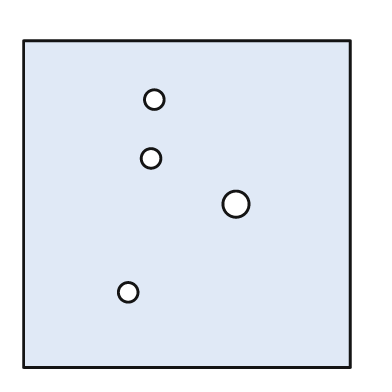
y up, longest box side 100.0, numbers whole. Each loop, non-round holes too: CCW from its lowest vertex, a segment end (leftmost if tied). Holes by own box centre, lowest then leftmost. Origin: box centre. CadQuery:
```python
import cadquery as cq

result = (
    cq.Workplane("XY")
    .moveTo(-50.0, -50.0)
    .lineTo(50.0, -50.0)
    .lineTo(50.0, 50.0)
    .lineTo(-50.0, 50.0)
    .close()
    .moveTo(-18.0, -27.0)
    .circle(3.0)
    .moveTo(15.0, 0.0)
    .circle(4.0)
    .moveTo(-11.0, 14.0)
    .circle(3.0)
    .moveTo(-10.0, 32.0)
    .circle(3.0)
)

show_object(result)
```